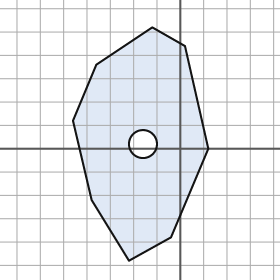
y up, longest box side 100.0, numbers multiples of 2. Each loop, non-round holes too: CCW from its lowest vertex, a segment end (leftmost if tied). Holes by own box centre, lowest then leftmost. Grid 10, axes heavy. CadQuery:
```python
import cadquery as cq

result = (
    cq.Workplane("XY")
    .moveTo(-22.0, -48.0)
    .lineTo(-4.0, -38.0)
    .lineTo(12.0, 0.0)
    .lineTo(2.0, 44.0)
    .lineTo(-12.0, 52.0)
    .lineTo(-36.0, 36.0)
    .lineTo(-46.0, 12.0)
    .lineTo(-38.0, -22.0)
    .close()
    .moveTo(-16.0, 2.0)
    .circle(6.0)
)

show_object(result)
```